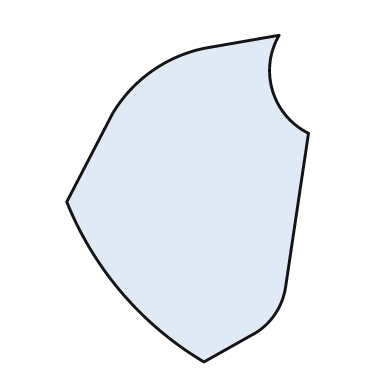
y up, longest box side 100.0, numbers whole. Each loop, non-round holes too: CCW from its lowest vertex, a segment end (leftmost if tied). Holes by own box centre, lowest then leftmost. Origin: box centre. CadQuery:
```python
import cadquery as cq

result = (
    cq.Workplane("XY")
    .moveTo(5.0, -50.0)
    .lineTo(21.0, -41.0)
    .threePointArc((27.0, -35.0), (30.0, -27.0))
    .lineTo(37.0, 20.0)
    .threePointArc((26.0, 33.0), (28.0, 50.0))
    .lineTo(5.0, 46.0)
    .threePointArc((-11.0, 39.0), (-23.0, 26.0))
    .lineTo(-37.0, -1.0)
    .threePointArc((-20.0, -29.0), (5.0, -50.0))
    .close()
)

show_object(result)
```